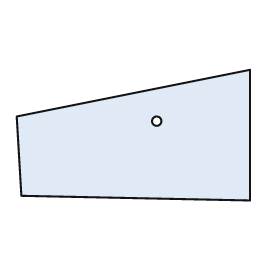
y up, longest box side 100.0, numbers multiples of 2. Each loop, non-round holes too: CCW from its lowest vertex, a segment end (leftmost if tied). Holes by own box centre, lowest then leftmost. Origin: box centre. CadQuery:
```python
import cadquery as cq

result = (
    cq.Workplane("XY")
    .moveTo(50.0, -28.0)
    .lineTo(50.0, 28.0)
    .lineTo(-50.0, 8.0)
    .lineTo(-48.0, -26.0)
    .close()
    .moveTo(10.0, 6.0)
    .circle(2.0)
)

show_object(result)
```